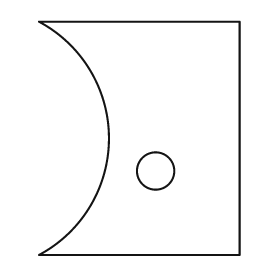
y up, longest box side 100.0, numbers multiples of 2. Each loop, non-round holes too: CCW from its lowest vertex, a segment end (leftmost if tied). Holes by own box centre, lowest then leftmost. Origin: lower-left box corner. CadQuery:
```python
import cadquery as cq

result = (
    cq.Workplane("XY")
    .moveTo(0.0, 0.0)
    .lineTo(86.0, 0.0)
    .lineTo(86.0, 100.0)
    .lineTo(0.0, 100.0)
    .threePointArc((30.0, 50.0), (0.0, 0.0))
    .close()
    .moveTo(50.0, 36.0)
    .circle(8.0)
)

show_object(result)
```